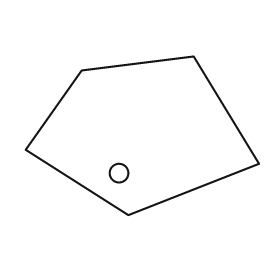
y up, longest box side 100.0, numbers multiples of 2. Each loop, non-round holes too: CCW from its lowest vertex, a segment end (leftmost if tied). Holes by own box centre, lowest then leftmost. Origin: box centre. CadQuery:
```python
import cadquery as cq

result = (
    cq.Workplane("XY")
    .moveTo(-6.0, -34.0)
    .lineTo(50.0, -12.0)
    .lineTo(22.0, 34.0)
    .lineTo(-26.0, 28.0)
    .lineTo(-50.0, -6.0)
    .close()
    .moveTo(-10.0, -16.0)
    .circle(4.0)
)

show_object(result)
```